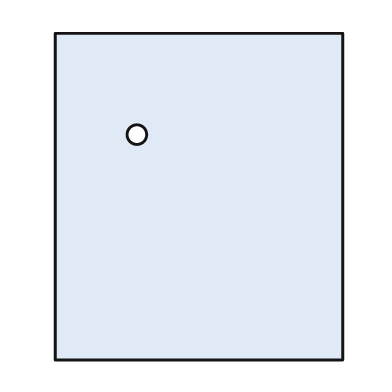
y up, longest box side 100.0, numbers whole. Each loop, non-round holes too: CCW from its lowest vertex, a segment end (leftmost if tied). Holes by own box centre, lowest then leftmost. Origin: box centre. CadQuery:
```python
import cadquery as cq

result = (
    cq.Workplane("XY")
    .moveTo(-44.0, -50.0)
    .lineTo(44.0, -50.0)
    .lineTo(44.0, 50.0)
    .lineTo(-44.0, 50.0)
    .close()
    .moveTo(-19.0, 19.0)
    .circle(3.0)
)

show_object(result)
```